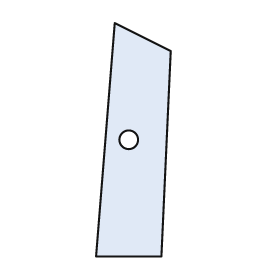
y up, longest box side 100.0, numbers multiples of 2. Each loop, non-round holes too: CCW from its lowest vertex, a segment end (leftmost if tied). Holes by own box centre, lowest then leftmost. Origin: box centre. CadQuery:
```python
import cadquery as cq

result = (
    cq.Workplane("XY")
    .moveTo(-16.0, -50.0)
    .lineTo(12.0, -50.0)
    .lineTo(16.0, 38.0)
    .lineTo(-8.0, 50.0)
    .close()
    .moveTo(-2.0, 0.0)
    .circle(4.0)
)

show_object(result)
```